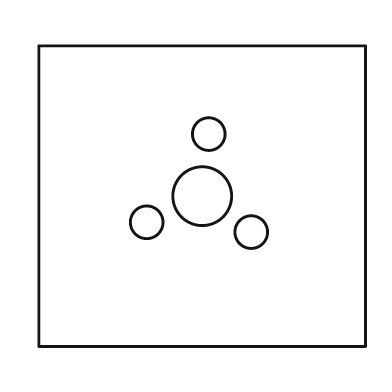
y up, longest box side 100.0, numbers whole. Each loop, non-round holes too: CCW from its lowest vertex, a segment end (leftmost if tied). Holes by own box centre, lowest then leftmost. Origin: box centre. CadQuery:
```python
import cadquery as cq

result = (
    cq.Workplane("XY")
    .moveTo(-50.0, -46.0)
    .lineTo(50.0, -46.0)
    .lineTo(50.0, 46.0)
    .lineTo(-50.0, 46.0)
    .close()
    .moveTo(15.0, -11.0)
    .circle(5.0)
    .moveTo(-17.0, -8.0)
    .circle(5.0)
    .moveTo(0.0, 0.0)
    .circle(9.0)
    .moveTo(2.0, 19.0)
    .circle(5.0)
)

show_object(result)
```